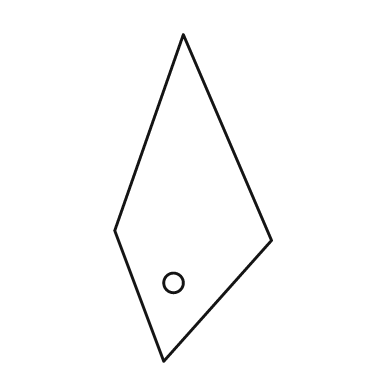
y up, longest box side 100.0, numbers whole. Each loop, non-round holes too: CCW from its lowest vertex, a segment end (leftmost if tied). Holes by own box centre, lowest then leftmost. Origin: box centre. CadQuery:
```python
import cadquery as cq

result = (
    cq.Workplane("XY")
    .moveTo(-9.0, -50.0)
    .lineTo(24.0, -13.0)
    .lineTo(-3.0, 50.0)
    .lineTo(-24.0, -10.0)
    .close()
    .moveTo(-6.0, -26.0)
    .circle(3.0)
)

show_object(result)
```